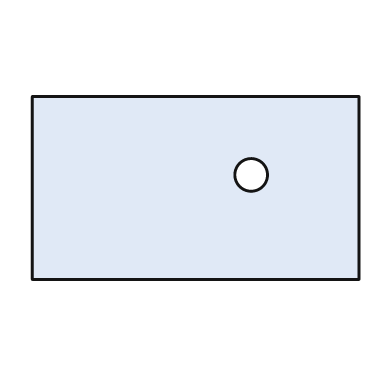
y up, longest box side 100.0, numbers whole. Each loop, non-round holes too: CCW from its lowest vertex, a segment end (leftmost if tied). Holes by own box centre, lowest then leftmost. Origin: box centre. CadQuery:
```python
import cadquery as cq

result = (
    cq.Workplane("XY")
    .moveTo(-50.0, -28.0)
    .lineTo(50.0, -28.0)
    .lineTo(50.0, 28.0)
    .lineTo(-50.0, 28.0)
    .close()
    .moveTo(17.0, 4.0)
    .circle(5.0)
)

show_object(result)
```